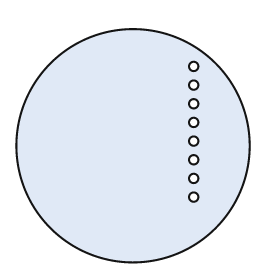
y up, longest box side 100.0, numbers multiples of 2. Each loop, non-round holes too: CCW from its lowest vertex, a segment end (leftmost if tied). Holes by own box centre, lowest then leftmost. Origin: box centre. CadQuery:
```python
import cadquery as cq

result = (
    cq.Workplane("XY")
    .moveTo(0.0, 0.0)
    .circle(50.0)
    .moveTo(26.0, -22.0)
    .circle(2.0)
    .moveTo(26.0, -14.0)
    .circle(2.0)
    .moveTo(26.0, -6.0)
    .circle(2.0)
    .moveTo(26.0, 2.0)
    .circle(2.0)
    .moveTo(26.0, 10.0)
    .circle(2.0)
    .moveTo(26.0, 18.0)
    .circle(2.0)
    .moveTo(26.0, 26.0)
    .circle(2.0)
    .moveTo(26.0, 34.0)
    .circle(2.0)
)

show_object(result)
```